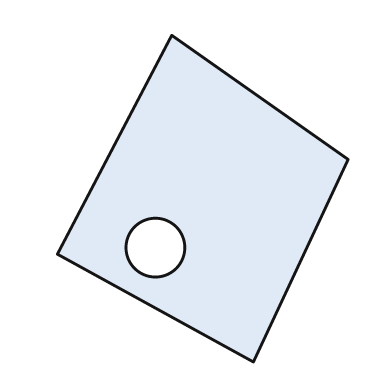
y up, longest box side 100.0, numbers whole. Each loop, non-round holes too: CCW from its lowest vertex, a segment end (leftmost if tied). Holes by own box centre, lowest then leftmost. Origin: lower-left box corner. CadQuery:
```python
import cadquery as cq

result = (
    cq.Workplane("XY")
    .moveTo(60.0, 0.0)
    .lineTo(89.0, 62.0)
    .lineTo(35.0, 100.0)
    .lineTo(0.0, 33.0)
    .close()
    .moveTo(30.0, 35.0)
    .circle(9.0)
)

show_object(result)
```